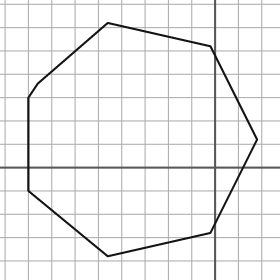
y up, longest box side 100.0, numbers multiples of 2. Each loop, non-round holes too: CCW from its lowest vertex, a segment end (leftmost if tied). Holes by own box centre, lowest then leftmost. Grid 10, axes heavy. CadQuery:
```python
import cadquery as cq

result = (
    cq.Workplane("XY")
    .moveTo(-46.0, -38.0)
    .lineTo(-2.0, -28.0)
    .lineTo(18.0, 12.0)
    .lineTo(-2.0, 52.0)
    .lineTo(-46.0, 62.0)
    .lineTo(-76.0, 36.0)
    .lineTo(-80.0, 30.0)
    .lineTo(-80.0, -10.0)
    .close()
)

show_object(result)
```